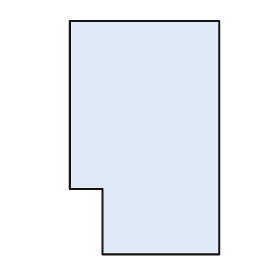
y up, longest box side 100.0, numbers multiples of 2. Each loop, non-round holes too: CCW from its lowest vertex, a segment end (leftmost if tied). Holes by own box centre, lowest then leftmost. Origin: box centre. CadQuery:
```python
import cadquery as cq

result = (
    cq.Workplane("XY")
    .moveTo(-18.0, -50.0)
    .lineTo(32.0, -50.0)
    .lineTo(32.0, 50.0)
    .lineTo(-32.0, 50.0)
    .lineTo(-32.0, -22.0)
    .lineTo(-18.0, -22.0)
    .close()
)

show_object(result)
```